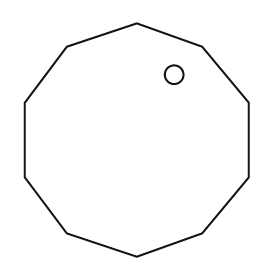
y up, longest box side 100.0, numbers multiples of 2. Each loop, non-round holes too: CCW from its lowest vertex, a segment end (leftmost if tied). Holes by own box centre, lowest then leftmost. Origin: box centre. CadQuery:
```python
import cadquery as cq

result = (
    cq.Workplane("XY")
    .moveTo(0.0, -50.0)
    .lineTo(28.0, -40.0)
    .lineTo(48.0, -16.0)
    .lineTo(48.0, 16.0)
    .lineTo(28.0, 40.0)
    .lineTo(0.0, 50.0)
    .lineTo(-30.0, 40.0)
    .lineTo(-48.0, 16.0)
    .lineTo(-48.0, -16.0)
    .lineTo(-30.0, -40.0)
    .close()
    .moveTo(16.0, 28.0)
    .circle(4.0)
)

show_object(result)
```